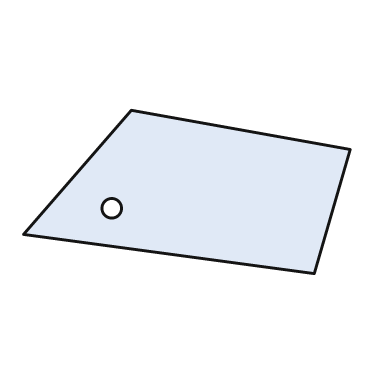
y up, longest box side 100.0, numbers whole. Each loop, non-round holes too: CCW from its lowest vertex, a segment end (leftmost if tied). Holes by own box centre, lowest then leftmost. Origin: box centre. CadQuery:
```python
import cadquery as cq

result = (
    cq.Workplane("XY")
    .moveTo(39.0, -25.0)
    .lineTo(50.0, 13.0)
    .lineTo(-17.0, 25.0)
    .lineTo(-50.0, -13.0)
    .close()
    .moveTo(-23.0, -5.0)
    .circle(3.0)
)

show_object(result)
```